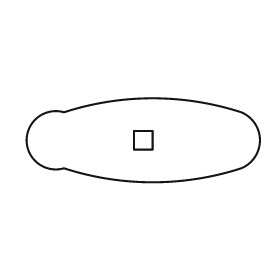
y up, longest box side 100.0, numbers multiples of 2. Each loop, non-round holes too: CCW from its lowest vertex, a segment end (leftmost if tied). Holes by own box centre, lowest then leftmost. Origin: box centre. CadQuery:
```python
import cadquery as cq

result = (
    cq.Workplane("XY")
    .moveTo(-34.0, -12.0)
    .threePointArc((4.0, -18.0), (42.0, -12.0))
    .threePointArc((50.0, 0.0), (42.0, 12.0))
    .threePointArc((4.0, 18.0), (-34.0, 12.0))
    .threePointArc((-50.0, 0.0), (-34.0, -12.0))
    .close()
    .moveTo(-4.0, -4.0)
    .lineTo(4.0, -4.0)
    .lineTo(4.0, 4.0)
    .lineTo(-4.0, 4.0)
    .close()
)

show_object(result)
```